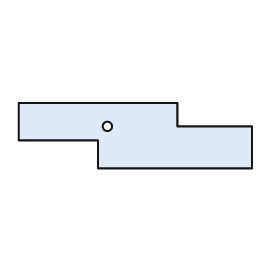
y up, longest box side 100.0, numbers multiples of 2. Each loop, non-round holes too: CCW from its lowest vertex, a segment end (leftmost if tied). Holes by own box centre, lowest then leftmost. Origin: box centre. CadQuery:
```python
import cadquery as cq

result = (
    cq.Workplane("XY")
    .moveTo(-16.0, -14.0)
    .lineTo(50.0, -14.0)
    .lineTo(50.0, 4.0)
    .lineTo(18.0, 4.0)
    .lineTo(18.0, 14.0)
    .lineTo(-50.0, 14.0)
    .lineTo(-50.0, -2.0)
    .lineTo(-16.0, -2.0)
    .close()
    .moveTo(-12.0, 4.0)
    .circle(2.0)
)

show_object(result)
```